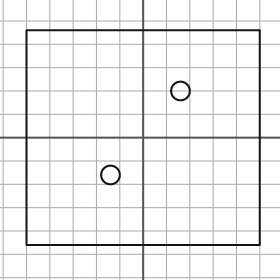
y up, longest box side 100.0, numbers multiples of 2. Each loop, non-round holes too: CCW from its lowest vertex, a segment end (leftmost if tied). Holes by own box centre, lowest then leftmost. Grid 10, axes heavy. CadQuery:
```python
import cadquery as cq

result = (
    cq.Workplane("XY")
    .moveTo(-50.0, -46.0)
    .lineTo(50.0, -46.0)
    .lineTo(50.0, 46.0)
    .lineTo(-50.0, 46.0)
    .close()
    .moveTo(-14.0, -16.0)
    .circle(4.0)
    .moveTo(16.0, 20.0)
    .circle(4.0)
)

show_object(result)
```